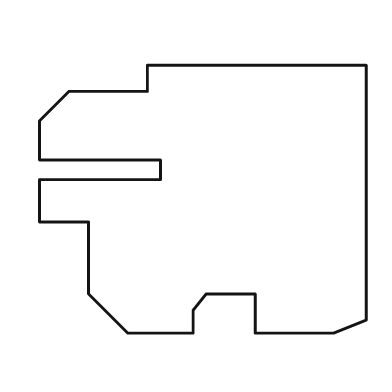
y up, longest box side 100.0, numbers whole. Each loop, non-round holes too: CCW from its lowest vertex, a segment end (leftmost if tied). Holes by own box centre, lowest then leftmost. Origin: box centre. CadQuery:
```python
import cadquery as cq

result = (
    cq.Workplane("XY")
    .moveTo(-23.0, -41.0)
    .lineTo(-3.0, -41.0)
    .lineTo(-3.0, -34.0)
    .lineTo(1.0, -29.0)
    .lineTo(16.0, -29.0)
    .lineTo(16.0, -41.0)
    .lineTo(40.0, -41.0)
    .lineTo(50.0, -37.0)
    .lineTo(50.0, 41.0)
    .lineTo(-17.0, 41.0)
    .lineTo(-17.0, 33.0)
    .lineTo(-41.0, 33.0)
    .lineTo(-50.0, 24.0)
    .lineTo(-50.0, 12.0)
    .lineTo(-13.0, 12.0)
    .lineTo(-13.0, 6.0)
    .lineTo(-50.0, 6.0)
    .lineTo(-50.0, -7.0)
    .lineTo(-35.0, -7.0)
    .lineTo(-35.0, -29.0)
    .close()
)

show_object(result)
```